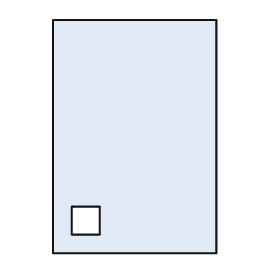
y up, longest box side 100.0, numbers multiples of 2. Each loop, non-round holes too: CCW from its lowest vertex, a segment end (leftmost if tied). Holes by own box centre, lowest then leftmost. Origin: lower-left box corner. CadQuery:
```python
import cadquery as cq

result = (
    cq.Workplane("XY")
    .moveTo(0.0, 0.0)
    .lineTo(70.0, 0.0)
    .lineTo(70.0, 100.0)
    .lineTo(0.0, 100.0)
    .close()
    .moveTo(8.0, 8.0)
    .lineTo(20.0, 8.0)
    .lineTo(20.0, 20.0)
    .lineTo(8.0, 20.0)
    .close()
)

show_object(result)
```